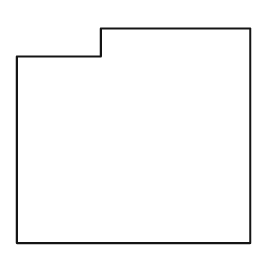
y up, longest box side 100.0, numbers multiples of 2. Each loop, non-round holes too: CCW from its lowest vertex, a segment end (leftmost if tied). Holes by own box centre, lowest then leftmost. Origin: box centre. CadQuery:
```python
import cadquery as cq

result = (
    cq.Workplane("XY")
    .moveTo(-50.0, -46.0)
    .lineTo(50.0, -46.0)
    .lineTo(50.0, 46.0)
    .lineTo(-14.0, 46.0)
    .lineTo(-14.0, 34.0)
    .lineTo(-50.0, 34.0)
    .close()
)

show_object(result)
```